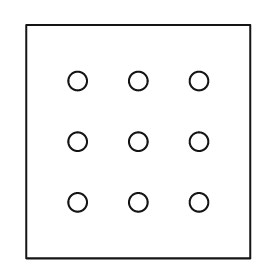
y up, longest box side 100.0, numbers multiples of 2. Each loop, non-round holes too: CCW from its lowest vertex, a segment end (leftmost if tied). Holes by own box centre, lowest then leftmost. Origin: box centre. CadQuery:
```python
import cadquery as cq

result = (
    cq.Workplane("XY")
    .moveTo(-48.0, -50.0)
    .lineTo(48.0, -50.0)
    .lineTo(48.0, 50.0)
    .lineTo(-48.0, 50.0)
    .close()
    .moveTo(-26.0, -26.0)
    .circle(4.0)
    .moveTo(0.0, -26.0)
    .circle(4.0)
    .moveTo(26.0, -26.0)
    .circle(4.0)
    .moveTo(-26.0, 0.0)
    .circle(4.0)
    .moveTo(0.0, 0.0)
    .circle(4.0)
    .moveTo(26.0, 0.0)
    .circle(4.0)
    .moveTo(-26.0, 26.0)
    .circle(4.0)
    .moveTo(0.0, 26.0)
    .circle(4.0)
    .moveTo(26.0, 26.0)
    .circle(4.0)
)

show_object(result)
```